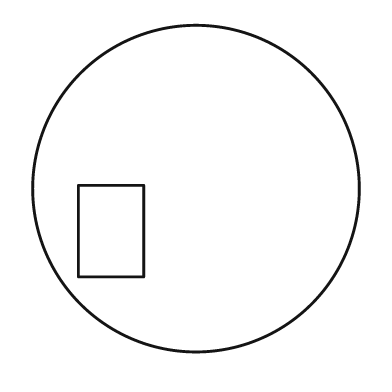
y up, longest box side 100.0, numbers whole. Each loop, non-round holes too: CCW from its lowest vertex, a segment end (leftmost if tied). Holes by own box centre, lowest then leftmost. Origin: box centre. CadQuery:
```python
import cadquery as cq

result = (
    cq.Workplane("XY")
    .moveTo(0.0, 0.0)
    .circle(50.0)
    .moveTo(-36.0, -27.0)
    .lineTo(-16.0, -27.0)
    .lineTo(-16.0, 1.0)
    .lineTo(-36.0, 1.0)
    .close()
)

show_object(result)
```